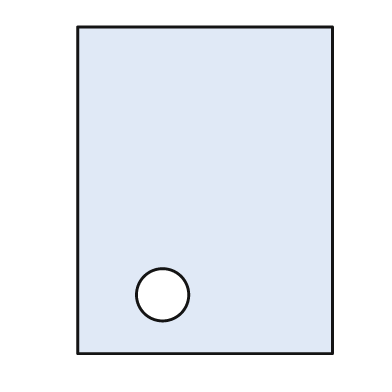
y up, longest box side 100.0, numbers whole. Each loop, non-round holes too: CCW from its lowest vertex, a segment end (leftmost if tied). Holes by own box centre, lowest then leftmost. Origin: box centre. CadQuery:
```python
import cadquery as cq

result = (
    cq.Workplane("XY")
    .moveTo(-39.0, -50.0)
    .lineTo(39.0, -50.0)
    .lineTo(39.0, 50.0)
    .lineTo(-39.0, 50.0)
    .close()
    .moveTo(-13.0, -32.0)
    .circle(8.0)
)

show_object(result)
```